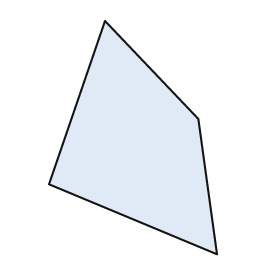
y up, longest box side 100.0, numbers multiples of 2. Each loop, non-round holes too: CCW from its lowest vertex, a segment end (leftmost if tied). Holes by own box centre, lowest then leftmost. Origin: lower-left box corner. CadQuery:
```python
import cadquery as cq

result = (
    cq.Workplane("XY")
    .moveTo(72.0, 0.0)
    .lineTo(64.0, 58.0)
    .lineTo(24.0, 100.0)
    .lineTo(0.0, 30.0)
    .close()
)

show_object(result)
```